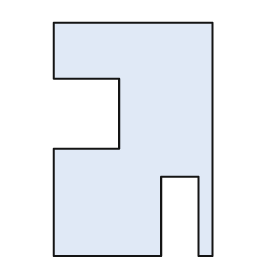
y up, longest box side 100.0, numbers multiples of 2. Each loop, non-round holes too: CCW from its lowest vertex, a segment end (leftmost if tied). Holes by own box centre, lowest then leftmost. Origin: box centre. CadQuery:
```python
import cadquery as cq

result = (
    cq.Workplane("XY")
    .moveTo(-34.0, -50.0)
    .lineTo(12.0, -50.0)
    .lineTo(12.0, -16.0)
    .lineTo(28.0, -16.0)
    .lineTo(28.0, -50.0)
    .lineTo(34.0, -50.0)
    .lineTo(34.0, 50.0)
    .lineTo(-34.0, 50.0)
    .lineTo(-34.0, 26.0)
    .lineTo(-6.0, 26.0)
    .lineTo(-6.0, -4.0)
    .lineTo(-34.0, -4.0)
    .close()
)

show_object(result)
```